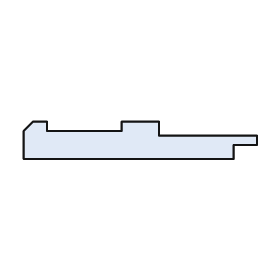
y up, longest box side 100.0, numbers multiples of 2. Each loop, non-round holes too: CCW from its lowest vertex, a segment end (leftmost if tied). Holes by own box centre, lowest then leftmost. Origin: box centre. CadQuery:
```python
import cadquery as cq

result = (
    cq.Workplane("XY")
    .moveTo(-50.0, -8.0)
    .lineTo(40.0, -8.0)
    .lineTo(40.0, -2.0)
    .lineTo(50.0, -2.0)
    .lineTo(50.0, 2.0)
    .lineTo(8.0, 2.0)
    .lineTo(8.0, 8.0)
    .lineTo(-8.0, 8.0)
    .lineTo(-8.0, 4.0)
    .lineTo(-40.0, 4.0)
    .lineTo(-40.0, 8.0)
    .lineTo(-46.0, 8.0)
    .lineTo(-50.0, 4.0)
    .close()
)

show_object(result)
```